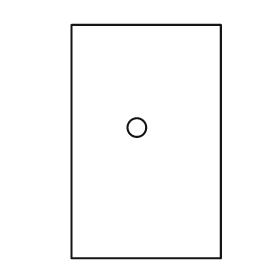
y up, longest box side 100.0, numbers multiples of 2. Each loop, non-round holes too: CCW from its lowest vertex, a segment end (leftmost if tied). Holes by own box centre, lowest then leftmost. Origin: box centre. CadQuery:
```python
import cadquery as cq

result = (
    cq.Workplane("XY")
    .moveTo(-32.0, -50.0)
    .lineTo(32.0, -50.0)
    .lineTo(32.0, 50.0)
    .lineTo(-32.0, 50.0)
    .close()
    .moveTo(-4.0, 6.0)
    .circle(4.0)
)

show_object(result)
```